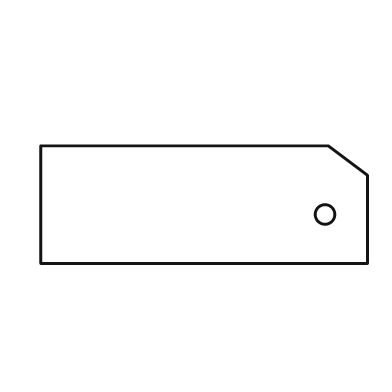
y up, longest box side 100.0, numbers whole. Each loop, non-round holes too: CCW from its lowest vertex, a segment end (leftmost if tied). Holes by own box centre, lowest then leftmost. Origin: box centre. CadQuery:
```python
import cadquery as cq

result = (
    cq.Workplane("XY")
    .moveTo(-50.0, -18.0)
    .lineTo(50.0, -18.0)
    .lineTo(50.0, 9.0)
    .lineTo(38.0, 18.0)
    .lineTo(-50.0, 18.0)
    .close()
    .moveTo(37.0, -3.0)
    .circle(3.0)
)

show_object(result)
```